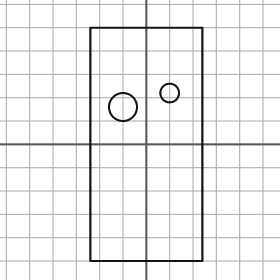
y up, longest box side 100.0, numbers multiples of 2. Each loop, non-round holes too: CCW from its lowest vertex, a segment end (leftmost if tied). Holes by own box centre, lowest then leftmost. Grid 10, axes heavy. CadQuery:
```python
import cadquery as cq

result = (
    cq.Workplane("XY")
    .moveTo(-24.0, -50.0)
    .lineTo(24.0, -50.0)
    .lineTo(24.0, 50.0)
    .lineTo(-24.0, 50.0)
    .close()
    .moveTo(-10.0, 16.0)
    .circle(6.0)
    .moveTo(10.0, 22.0)
    .circle(4.0)
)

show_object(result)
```